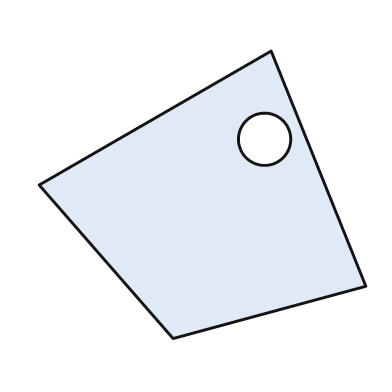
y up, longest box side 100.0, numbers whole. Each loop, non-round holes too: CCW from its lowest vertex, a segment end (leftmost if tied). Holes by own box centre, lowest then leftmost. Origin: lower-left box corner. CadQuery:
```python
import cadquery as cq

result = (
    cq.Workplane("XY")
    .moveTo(41.0, 0.0)
    .lineTo(100.0, 16.0)
    .lineTo(71.0, 88.0)
    .lineTo(0.0, 47.0)
    .close()
    .moveTo(69.0, 61.0)
    .circle(8.0)
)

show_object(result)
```